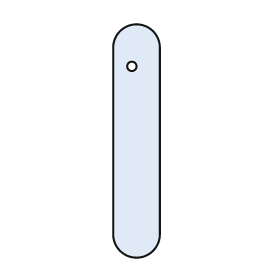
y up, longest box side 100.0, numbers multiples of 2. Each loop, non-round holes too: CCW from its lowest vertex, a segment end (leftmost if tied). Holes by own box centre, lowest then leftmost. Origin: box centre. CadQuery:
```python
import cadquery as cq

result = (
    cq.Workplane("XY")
    .moveTo(-10.0, -40.0)
    .threePointArc((0.0, -50.0), (10.0, -40.0))
    .lineTo(10.0, 40.0)
    .threePointArc((0.0, 50.0), (-10.0, 40.0))
    .close()
    .moveTo(-2.0, 32.0)
    .circle(2.0)
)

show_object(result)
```